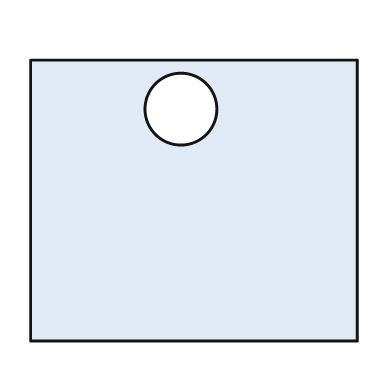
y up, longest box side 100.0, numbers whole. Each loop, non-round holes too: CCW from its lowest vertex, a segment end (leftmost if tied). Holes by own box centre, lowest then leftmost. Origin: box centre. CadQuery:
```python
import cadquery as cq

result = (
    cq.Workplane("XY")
    .moveTo(-50.0, -43.0)
    .lineTo(50.0, -43.0)
    .lineTo(50.0, 43.0)
    .lineTo(-50.0, 43.0)
    .close()
    .moveTo(-4.0, 28.0)
    .circle(11.0)
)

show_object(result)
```